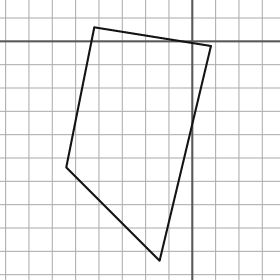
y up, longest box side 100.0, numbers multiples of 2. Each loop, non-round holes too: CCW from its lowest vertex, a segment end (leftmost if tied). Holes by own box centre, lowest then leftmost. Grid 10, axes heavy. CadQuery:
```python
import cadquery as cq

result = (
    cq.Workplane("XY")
    .moveTo(-14.0, -94.0)
    .lineTo(8.0, -2.0)
    .lineTo(-42.0, 6.0)
    .lineTo(-54.0, -54.0)
    .close()
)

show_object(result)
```